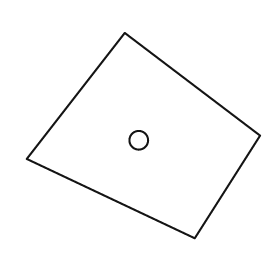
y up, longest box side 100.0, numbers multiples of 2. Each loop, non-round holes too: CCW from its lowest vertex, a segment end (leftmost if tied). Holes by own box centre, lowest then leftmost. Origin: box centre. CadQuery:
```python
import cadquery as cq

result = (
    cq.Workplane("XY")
    .moveTo(22.0, -44.0)
    .lineTo(50.0, 0.0)
    .lineTo(-8.0, 44.0)
    .lineTo(-50.0, -10.0)
    .close()
    .moveTo(-2.0, -2.0)
    .circle(4.0)
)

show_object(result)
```